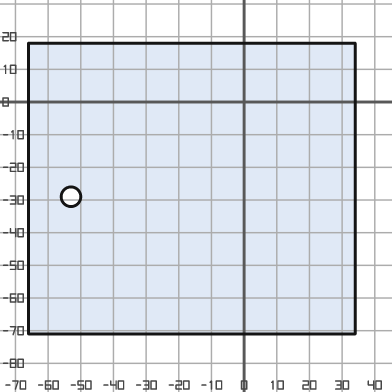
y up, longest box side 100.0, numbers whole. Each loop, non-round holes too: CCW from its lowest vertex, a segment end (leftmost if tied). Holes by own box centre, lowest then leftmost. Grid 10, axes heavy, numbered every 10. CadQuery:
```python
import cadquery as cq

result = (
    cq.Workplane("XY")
    .moveTo(-66.0, -71.0)
    .lineTo(34.0, -71.0)
    .lineTo(34.0, 18.0)
    .lineTo(-66.0, 18.0)
    .close()
    .moveTo(-53.0, -29.0)
    .circle(3.0)
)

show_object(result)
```